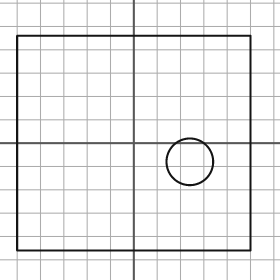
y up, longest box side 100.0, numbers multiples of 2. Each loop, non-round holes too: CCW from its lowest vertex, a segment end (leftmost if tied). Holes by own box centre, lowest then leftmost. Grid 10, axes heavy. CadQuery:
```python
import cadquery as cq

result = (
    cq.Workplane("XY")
    .moveTo(-50.0, -46.0)
    .lineTo(50.0, -46.0)
    .lineTo(50.0, 46.0)
    .lineTo(-50.0, 46.0)
    .close()
    .moveTo(24.0, -8.0)
    .circle(10.0)
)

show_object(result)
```